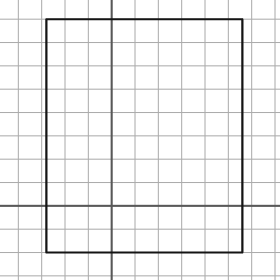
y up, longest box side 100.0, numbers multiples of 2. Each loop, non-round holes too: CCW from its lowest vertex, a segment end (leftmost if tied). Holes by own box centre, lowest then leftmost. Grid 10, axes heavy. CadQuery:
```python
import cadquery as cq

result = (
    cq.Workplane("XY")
    .moveTo(-28.0, -20.0)
    .lineTo(56.0, -20.0)
    .lineTo(56.0, 80.0)
    .lineTo(-28.0, 80.0)
    .close()
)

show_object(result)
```